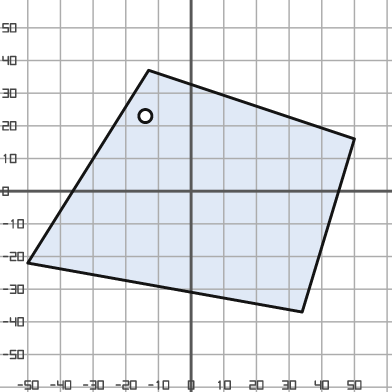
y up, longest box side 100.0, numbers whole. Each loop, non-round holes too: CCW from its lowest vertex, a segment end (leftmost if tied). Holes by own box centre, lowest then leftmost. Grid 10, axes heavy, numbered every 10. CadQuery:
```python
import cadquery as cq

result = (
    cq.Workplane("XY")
    .moveTo(34.0, -37.0)
    .lineTo(50.0, 16.0)
    .lineTo(-13.0, 37.0)
    .lineTo(-50.0, -22.0)
    .close()
    .moveTo(-14.0, 23.0)
    .circle(2.0)
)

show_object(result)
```